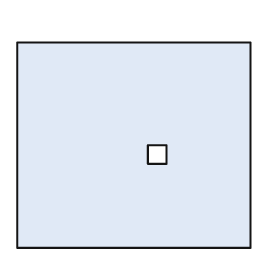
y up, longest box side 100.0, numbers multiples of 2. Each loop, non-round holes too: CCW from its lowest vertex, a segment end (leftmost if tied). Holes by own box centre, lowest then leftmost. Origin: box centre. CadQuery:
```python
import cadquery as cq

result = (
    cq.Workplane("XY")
    .moveTo(-50.0, -44.0)
    .lineTo(50.0, -44.0)
    .lineTo(50.0, 44.0)
    .lineTo(-50.0, 44.0)
    .close()
    .moveTo(6.0, -8.0)
    .lineTo(14.0, -8.0)
    .lineTo(14.0, 0.0)
    .lineTo(6.0, 0.0)
    .close()
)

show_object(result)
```